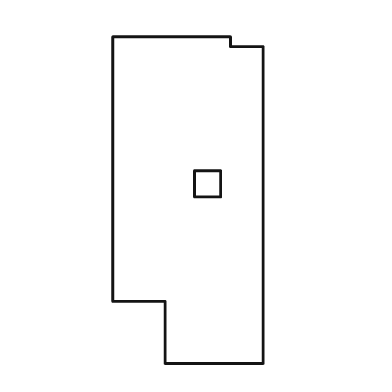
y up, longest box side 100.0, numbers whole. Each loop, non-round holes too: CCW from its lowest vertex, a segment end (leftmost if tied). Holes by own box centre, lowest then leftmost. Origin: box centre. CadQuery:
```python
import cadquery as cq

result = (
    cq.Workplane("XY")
    .moveTo(-7.0, -50.0)
    .lineTo(23.0, -50.0)
    .lineTo(23.0, 47.0)
    .lineTo(13.0, 47.0)
    .lineTo(13.0, 50.0)
    .lineTo(-23.0, 50.0)
    .lineTo(-23.0, -31.0)
    .lineTo(-7.0, -31.0)
    .close()
    .moveTo(2.0, 1.0)
    .lineTo(10.0, 1.0)
    .lineTo(10.0, 9.0)
    .lineTo(2.0, 9.0)
    .close()
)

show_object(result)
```